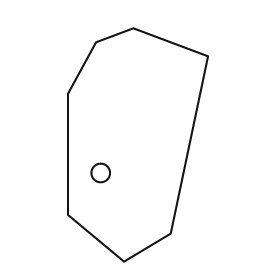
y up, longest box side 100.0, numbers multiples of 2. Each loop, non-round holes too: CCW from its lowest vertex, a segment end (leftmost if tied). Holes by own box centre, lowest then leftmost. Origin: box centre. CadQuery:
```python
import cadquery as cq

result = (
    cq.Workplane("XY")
    .moveTo(-6.0, -50.0)
    .lineTo(14.0, -38.0)
    .lineTo(30.0, 38.0)
    .lineTo(-2.0, 50.0)
    .lineTo(-18.0, 44.0)
    .lineTo(-30.0, 22.0)
    .lineTo(-30.0, -30.0)
    .close()
    .moveTo(-16.0, -12.0)
    .circle(4.0)
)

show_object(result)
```